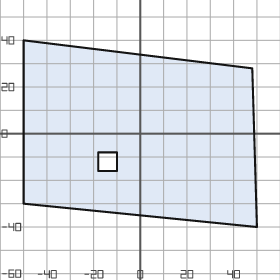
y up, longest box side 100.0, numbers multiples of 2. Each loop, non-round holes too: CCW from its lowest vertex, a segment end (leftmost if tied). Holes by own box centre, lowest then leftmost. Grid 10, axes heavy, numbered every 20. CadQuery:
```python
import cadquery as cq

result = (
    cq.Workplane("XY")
    .moveTo(50.0, -40.0)
    .lineTo(48.0, 28.0)
    .lineTo(-50.0, 40.0)
    .lineTo(-50.0, -30.0)
    .close()
    .moveTo(-18.0, -16.0)
    .lineTo(-10.0, -16.0)
    .lineTo(-10.0, -8.0)
    .lineTo(-18.0, -8.0)
    .close()
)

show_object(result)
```